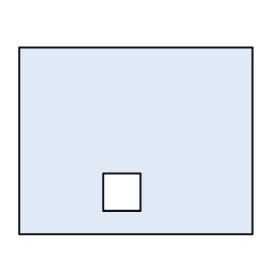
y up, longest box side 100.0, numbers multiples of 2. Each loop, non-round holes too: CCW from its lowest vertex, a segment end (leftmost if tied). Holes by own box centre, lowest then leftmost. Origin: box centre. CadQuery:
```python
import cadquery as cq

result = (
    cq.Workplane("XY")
    .moveTo(-50.0, -40.0)
    .lineTo(50.0, -40.0)
    .lineTo(50.0, 40.0)
    .lineTo(-50.0, 40.0)
    .close()
    .moveTo(-14.0, -30.0)
    .lineTo(2.0, -30.0)
    .lineTo(2.0, -14.0)
    .lineTo(-14.0, -14.0)
    .close()
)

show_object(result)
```